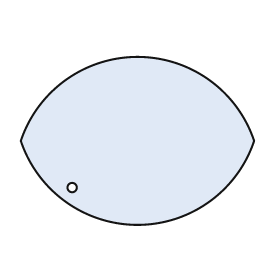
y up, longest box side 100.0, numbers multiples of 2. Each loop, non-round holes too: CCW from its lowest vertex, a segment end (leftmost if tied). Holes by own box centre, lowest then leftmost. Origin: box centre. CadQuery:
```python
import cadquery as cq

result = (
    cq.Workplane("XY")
    .moveTo(-50.0, 0.0)
    .threePointArc((0.0, -36.0), (50.0, 0.0))
    .threePointArc((0.0, 36.0), (-50.0, 0.0))
    .close()
    .moveTo(-28.0, -20.0)
    .circle(2.0)
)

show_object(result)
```